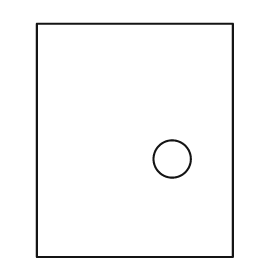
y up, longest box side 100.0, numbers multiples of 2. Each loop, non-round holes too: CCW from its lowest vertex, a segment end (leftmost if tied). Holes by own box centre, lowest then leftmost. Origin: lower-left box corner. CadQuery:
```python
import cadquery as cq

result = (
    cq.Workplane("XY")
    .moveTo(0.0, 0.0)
    .lineTo(84.0, 0.0)
    .lineTo(84.0, 100.0)
    .lineTo(0.0, 100.0)
    .close()
    .moveTo(58.0, 42.0)
    .circle(8.0)
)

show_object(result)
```